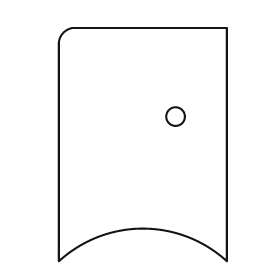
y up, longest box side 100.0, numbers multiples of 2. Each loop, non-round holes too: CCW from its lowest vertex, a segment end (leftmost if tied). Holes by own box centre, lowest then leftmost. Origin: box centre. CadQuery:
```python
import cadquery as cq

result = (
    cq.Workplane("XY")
    .moveTo(-36.0, -50.0)
    .threePointArc((0.0, -36.0), (36.0, -50.0))
    .lineTo(36.0, 50.0)
    .lineTo(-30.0, 50.0)
    .threePointArc((-34.0, 48.0), (-36.0, 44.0))
    .close()
    .moveTo(14.0, 12.0)
    .circle(4.0)
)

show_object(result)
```